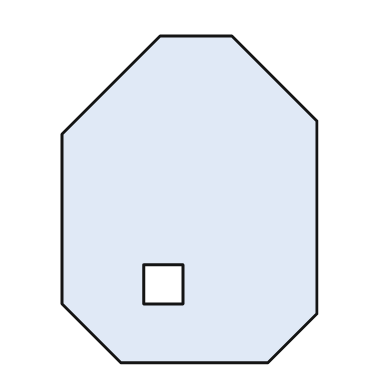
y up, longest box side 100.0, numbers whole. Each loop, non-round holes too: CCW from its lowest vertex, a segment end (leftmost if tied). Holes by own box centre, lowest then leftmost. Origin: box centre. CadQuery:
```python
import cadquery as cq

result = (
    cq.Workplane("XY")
    .moveTo(-21.0, -50.0)
    .lineTo(24.0, -50.0)
    .lineTo(39.0, -35.0)
    .lineTo(39.0, 24.0)
    .lineTo(13.0, 50.0)
    .lineTo(-9.0, 50.0)
    .lineTo(-39.0, 20.0)
    .lineTo(-39.0, -32.0)
    .close()
    .moveTo(-14.0, -32.0)
    .lineTo(-2.0, -32.0)
    .lineTo(-2.0, -20.0)
    .lineTo(-14.0, -20.0)
    .close()
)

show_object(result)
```